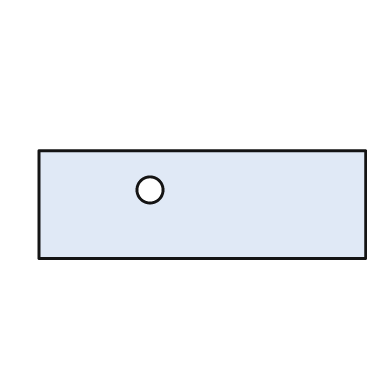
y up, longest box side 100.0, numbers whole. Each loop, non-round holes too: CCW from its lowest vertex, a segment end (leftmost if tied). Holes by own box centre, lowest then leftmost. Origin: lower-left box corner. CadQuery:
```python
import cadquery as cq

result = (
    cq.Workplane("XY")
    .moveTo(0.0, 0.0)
    .lineTo(100.0, 0.0)
    .lineTo(100.0, 33.0)
    .lineTo(0.0, 33.0)
    .close()
    .moveTo(34.0, 21.0)
    .circle(4.0)
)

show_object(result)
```